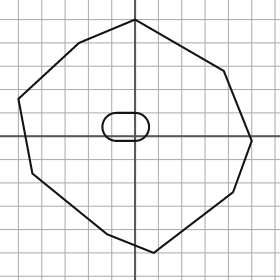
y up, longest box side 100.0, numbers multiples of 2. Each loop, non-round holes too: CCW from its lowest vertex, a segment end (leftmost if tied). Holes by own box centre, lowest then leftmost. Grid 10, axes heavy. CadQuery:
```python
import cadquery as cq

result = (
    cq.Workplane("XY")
    .moveTo(8.0, -50.0)
    .lineTo(42.0, -24.0)
    .lineTo(50.0, -2.0)
    .lineTo(38.0, 28.0)
    .lineTo(0.0, 50.0)
    .lineTo(-24.0, 40.0)
    .lineTo(-50.0, 16.0)
    .lineTo(-44.0, -16.0)
    .lineTo(-12.0, -42.0)
    .close()
    .moveTo(-8.0, -2.0)
    .lineTo(0.0, -2.0)
    .threePointArc((6.0, 4.0), (0.0, 10.0))
    .lineTo(-8.0, 10.0)
    .threePointArc((-14.0, 4.0), (-8.0, -2.0))
    .close()
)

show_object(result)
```